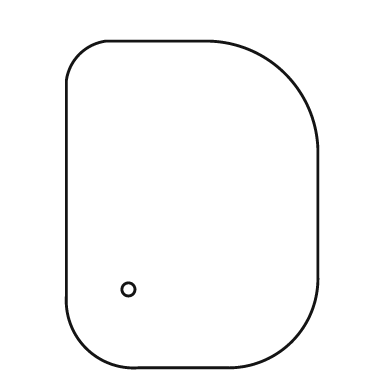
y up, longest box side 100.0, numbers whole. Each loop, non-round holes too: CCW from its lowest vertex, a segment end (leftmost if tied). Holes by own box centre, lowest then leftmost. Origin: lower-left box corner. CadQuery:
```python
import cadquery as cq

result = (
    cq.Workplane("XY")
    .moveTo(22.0, 0.0)
    .lineTo(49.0, 0.0)
    .threePointArc((69.0, 8.0), (77.0, 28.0))
    .lineTo(77.0, 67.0)
    .threePointArc((67.0, 90.0), (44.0, 100.0))
    .lineTo(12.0, 100.0)
    .threePointArc((4.0, 96.0), (0.0, 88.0))
    .lineTo(0.0, 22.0)
    .threePointArc((6.0, 6.0), (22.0, 0.0))
    .close()
    .moveTo(19.0, 24.0)
    .circle(2.0)
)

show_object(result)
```